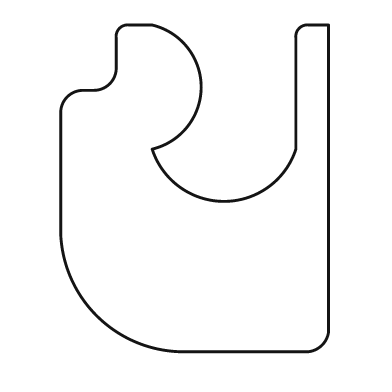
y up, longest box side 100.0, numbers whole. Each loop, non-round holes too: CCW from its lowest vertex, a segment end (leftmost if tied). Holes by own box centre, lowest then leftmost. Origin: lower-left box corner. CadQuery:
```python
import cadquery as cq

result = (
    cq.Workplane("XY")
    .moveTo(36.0, 0.0)
    .lineTo(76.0, 0.0)
    .threePointArc((80.0, 2.0), (82.0, 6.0))
    .lineTo(82.0, 100.0)
    .lineTo(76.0, 100.0)
    .threePointArc((73.0, 99.0), (72.0, 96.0))
    .lineTo(72.0, 62.0)
    .threePointArc((50.0, 46.0), (28.0, 62.0))
    .threePointArc((43.0, 81.0), (28.0, 100.0))
    .lineTo(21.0, 100.0)
    .threePointArc((18.0, 99.0), (17.0, 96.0))
    .lineTo(17.0, 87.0)
    .threePointArc((15.0, 82.0), (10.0, 80.0))
    .lineTo(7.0, 80.0)
    .threePointArc((2.0, 78.0), (0.0, 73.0))
    .lineTo(0.0, 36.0)
    .threePointArc((11.0, 11.0), (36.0, 0.0))
    .close()
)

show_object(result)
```